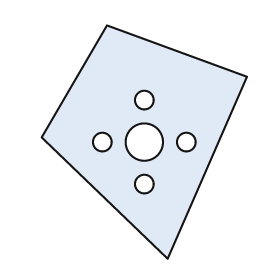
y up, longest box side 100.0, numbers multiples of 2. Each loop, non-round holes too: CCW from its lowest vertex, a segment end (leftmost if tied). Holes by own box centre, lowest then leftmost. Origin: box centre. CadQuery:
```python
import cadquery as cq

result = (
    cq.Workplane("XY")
    .moveTo(10.0, -50.0)
    .lineTo(44.0, 28.0)
    .lineTo(-16.0, 50.0)
    .lineTo(-44.0, 2.0)
    .close()
    .moveTo(0.0, -18.0)
    .circle(4.0)
    .moveTo(-18.0, 0.0)
    .circle(4.0)
    .moveTo(0.0, 0.0)
    .circle(8.0)
    .moveTo(18.0, 0.0)
    .circle(4.0)
    .moveTo(0.0, 18.0)
    .circle(4.0)
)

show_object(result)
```